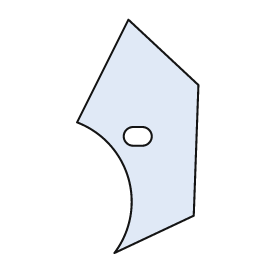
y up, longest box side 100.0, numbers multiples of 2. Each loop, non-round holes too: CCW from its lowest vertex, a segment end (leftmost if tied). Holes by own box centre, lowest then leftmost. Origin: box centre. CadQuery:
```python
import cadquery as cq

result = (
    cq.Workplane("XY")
    .moveTo(-10.0, -50.0)
    .lineTo(24.0, -34.0)
    .lineTo(26.0, 22.0)
    .lineTo(-4.0, 50.0)
    .lineTo(-26.0, 6.0)
    .threePointArc((-4.0, -18.0), (-10.0, -50.0))
    .close()
    .moveTo(-2.0, -4.0)
    .lineTo(2.0, -4.0)
    .threePointArc((6.0, 0.0), (2.0, 4.0))
    .lineTo(-2.0, 4.0)
    .threePointArc((-6.0, 0.0), (-2.0, -4.0))
    .close()
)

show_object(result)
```